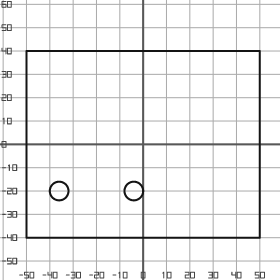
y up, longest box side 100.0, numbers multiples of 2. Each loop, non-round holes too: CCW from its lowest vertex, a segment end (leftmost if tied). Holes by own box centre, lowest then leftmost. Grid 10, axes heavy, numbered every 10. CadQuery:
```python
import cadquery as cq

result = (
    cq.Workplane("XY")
    .moveTo(-50.0, -40.0)
    .lineTo(50.0, -40.0)
    .lineTo(50.0, 40.0)
    .lineTo(-50.0, 40.0)
    .close()
    .moveTo(-36.0, -20.0)
    .circle(4.0)
    .moveTo(-4.0, -20.0)
    .circle(4.0)
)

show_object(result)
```